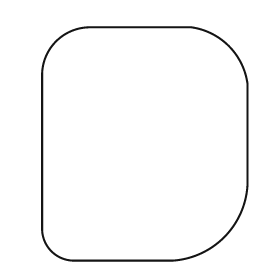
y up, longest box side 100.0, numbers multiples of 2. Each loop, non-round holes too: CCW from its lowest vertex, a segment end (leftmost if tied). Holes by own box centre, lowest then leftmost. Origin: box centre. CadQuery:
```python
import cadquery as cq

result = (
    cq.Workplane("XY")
    .moveTo(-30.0, -50.0)
    .lineTo(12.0, -50.0)
    .threePointArc((34.0, -40.0), (44.0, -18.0))
    .lineTo(44.0, 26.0)
    .threePointArc((36.0, 42.0), (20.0, 50.0))
    .lineTo(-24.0, 50.0)
    .threePointArc((-38.0, 44.0), (-44.0, 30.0))
    .lineTo(-44.0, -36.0)
    .threePointArc((-40.0, -46.0), (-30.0, -50.0))
    .close()
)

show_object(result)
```